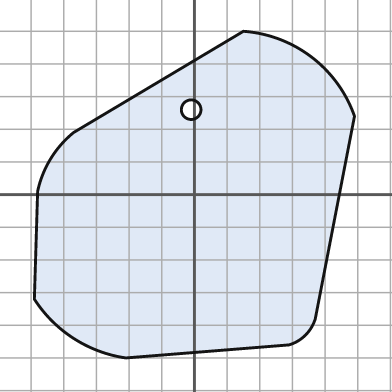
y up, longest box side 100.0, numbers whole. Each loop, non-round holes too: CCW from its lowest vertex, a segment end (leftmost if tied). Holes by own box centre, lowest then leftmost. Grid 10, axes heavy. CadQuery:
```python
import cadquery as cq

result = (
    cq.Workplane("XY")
    .moveTo(-21.0, -50.0)
    .lineTo(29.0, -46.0)
    .threePointArc((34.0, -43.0), (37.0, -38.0))
    .lineTo(49.0, 24.0)
    .threePointArc((36.0, 42.0), (15.0, 50.0))
    .lineTo(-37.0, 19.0)
    .threePointArc((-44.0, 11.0), (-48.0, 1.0))
    .lineTo(-49.0, -32.0)
    .threePointArc((-37.0, -44.0), (-21.0, -50.0))
    .close()
    .moveTo(-1.0, 26.0)
    .circle(3.0)
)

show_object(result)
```